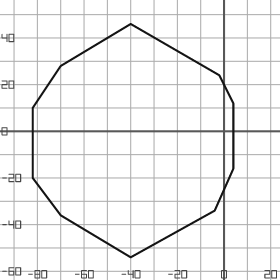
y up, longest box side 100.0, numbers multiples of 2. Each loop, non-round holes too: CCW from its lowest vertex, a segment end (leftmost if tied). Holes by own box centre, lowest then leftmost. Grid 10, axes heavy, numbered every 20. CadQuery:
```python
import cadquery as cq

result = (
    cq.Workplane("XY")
    .moveTo(-40.0, -54.0)
    .lineTo(-4.0, -34.0)
    .lineTo(4.0, -16.0)
    .lineTo(4.0, 12.0)
    .lineTo(-2.0, 24.0)
    .lineTo(-40.0, 46.0)
    .lineTo(-70.0, 28.0)
    .lineTo(-82.0, 10.0)
    .lineTo(-82.0, -20.0)
    .lineTo(-70.0, -36.0)
    .close()
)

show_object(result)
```